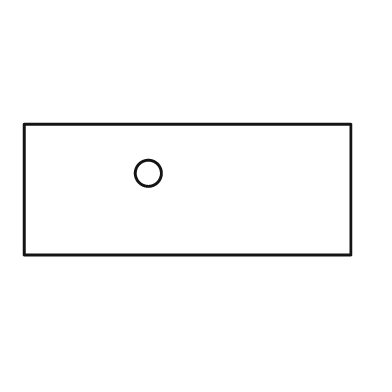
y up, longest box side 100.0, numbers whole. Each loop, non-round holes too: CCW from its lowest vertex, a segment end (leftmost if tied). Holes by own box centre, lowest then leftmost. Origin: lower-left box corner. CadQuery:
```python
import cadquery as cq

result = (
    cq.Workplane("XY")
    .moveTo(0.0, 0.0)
    .lineTo(100.0, 0.0)
    .lineTo(100.0, 40.0)
    .lineTo(0.0, 40.0)
    .close()
    .moveTo(38.0, 25.0)
    .circle(4.0)
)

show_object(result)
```